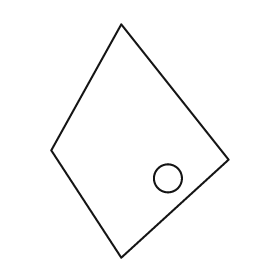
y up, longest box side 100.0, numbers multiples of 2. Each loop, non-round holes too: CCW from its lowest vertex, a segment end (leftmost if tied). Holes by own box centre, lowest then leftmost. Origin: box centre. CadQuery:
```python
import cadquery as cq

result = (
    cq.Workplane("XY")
    .moveTo(-8.0, -50.0)
    .lineTo(38.0, -8.0)
    .lineTo(-8.0, 50.0)
    .lineTo(-38.0, -4.0)
    .close()
    .moveTo(12.0, -16.0)
    .circle(6.0)
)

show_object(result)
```